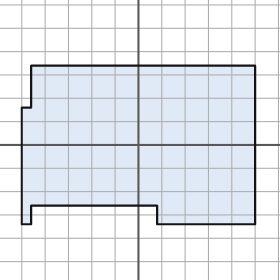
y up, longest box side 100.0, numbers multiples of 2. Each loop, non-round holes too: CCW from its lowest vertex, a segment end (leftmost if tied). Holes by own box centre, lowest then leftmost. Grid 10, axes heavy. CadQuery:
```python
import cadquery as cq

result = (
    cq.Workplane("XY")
    .moveTo(-50.0, -34.0)
    .lineTo(-46.0, -34.0)
    .lineTo(-46.0, -26.0)
    .lineTo(8.0, -26.0)
    .lineTo(8.0, -34.0)
    .lineTo(50.0, -34.0)
    .lineTo(50.0, 34.0)
    .lineTo(-46.0, 34.0)
    .lineTo(-46.0, 16.0)
    .lineTo(-50.0, 16.0)
    .close()
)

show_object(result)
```